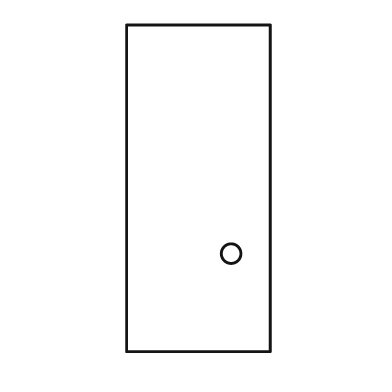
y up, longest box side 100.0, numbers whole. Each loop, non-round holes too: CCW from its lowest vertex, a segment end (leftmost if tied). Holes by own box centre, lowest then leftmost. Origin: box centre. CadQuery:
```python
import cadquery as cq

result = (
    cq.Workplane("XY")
    .moveTo(-22.0, -50.0)
    .lineTo(22.0, -50.0)
    .lineTo(22.0, 50.0)
    .lineTo(-22.0, 50.0)
    .close()
    .moveTo(10.0, -20.0)
    .circle(3.0)
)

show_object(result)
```